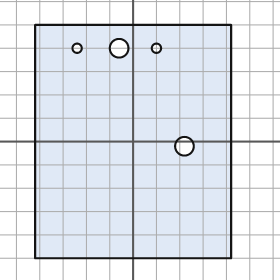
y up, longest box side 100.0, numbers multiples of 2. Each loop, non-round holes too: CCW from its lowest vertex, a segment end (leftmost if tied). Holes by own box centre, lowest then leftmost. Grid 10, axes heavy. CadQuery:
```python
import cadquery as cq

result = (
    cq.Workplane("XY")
    .moveTo(-42.0, -50.0)
    .lineTo(42.0, -50.0)
    .lineTo(42.0, 50.0)
    .lineTo(-42.0, 50.0)
    .close()
    .moveTo(22.0, -2.0)
    .circle(4.0)
    .moveTo(-24.0, 40.0)
    .circle(2.0)
    .moveTo(-6.0, 40.0)
    .circle(4.0)
    .moveTo(10.0, 40.0)
    .circle(2.0)
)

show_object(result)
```